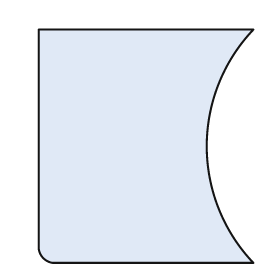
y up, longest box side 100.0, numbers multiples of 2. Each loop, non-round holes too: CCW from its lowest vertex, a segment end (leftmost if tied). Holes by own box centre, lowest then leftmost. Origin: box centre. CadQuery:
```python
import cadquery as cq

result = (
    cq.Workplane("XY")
    .moveTo(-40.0, -50.0)
    .lineTo(46.0, -50.0)
    .threePointArc((26.0, 0.0), (46.0, 50.0))
    .lineTo(-46.0, 50.0)
    .lineTo(-46.0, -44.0)
    .threePointArc((-44.0, -48.0), (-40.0, -50.0))
    .close()
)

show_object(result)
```